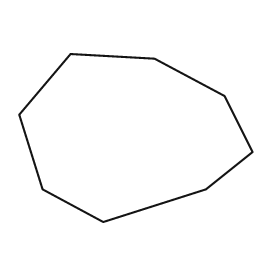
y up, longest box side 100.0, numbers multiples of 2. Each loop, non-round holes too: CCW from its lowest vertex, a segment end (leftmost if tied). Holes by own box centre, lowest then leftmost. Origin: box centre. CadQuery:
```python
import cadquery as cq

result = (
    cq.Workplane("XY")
    .moveTo(-14.0, -36.0)
    .lineTo(30.0, -22.0)
    .lineTo(50.0, -6.0)
    .lineTo(38.0, 18.0)
    .lineTo(8.0, 34.0)
    .lineTo(-28.0, 36.0)
    .lineTo(-50.0, 10.0)
    .lineTo(-40.0, -22.0)
    .close()
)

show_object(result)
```